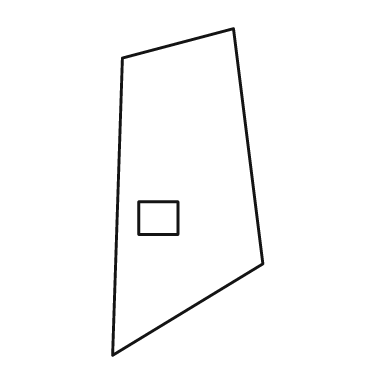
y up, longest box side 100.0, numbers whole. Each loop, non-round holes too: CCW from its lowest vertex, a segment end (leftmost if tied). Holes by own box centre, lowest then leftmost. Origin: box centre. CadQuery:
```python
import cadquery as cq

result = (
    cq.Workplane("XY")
    .moveTo(-23.0, -50.0)
    .lineTo(23.0, -22.0)
    .lineTo(14.0, 50.0)
    .lineTo(-20.0, 41.0)
    .close()
    .moveTo(-15.0, -13.0)
    .lineTo(-3.0, -13.0)
    .lineTo(-3.0, -3.0)
    .lineTo(-15.0, -3.0)
    .close()
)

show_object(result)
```